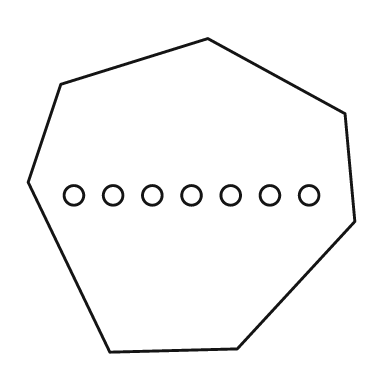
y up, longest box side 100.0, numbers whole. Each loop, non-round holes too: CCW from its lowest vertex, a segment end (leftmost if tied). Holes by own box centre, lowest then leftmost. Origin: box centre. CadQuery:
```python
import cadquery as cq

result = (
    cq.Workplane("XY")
    .moveTo(-25.0, -48.0)
    .lineTo(14.0, -47.0)
    .lineTo(50.0, -8.0)
    .lineTo(47.0, 25.0)
    .lineTo(5.0, 48.0)
    .lineTo(-40.0, 34.0)
    .lineTo(-50.0, 4.0)
    .close()
    .moveTo(-36.0, 0.0)
    .circle(3.0)
    .moveTo(-24.0, 0.0)
    .circle(3.0)
    .moveTo(-12.0, 0.0)
    .circle(3.0)
    .moveTo(0.0, 0.0)
    .circle(3.0)
    .moveTo(12.0, 0.0)
    .circle(3.0)
    .moveTo(24.0, 0.0)
    .circle(3.0)
    .moveTo(36.0, 0.0)
    .circle(3.0)
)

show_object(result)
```